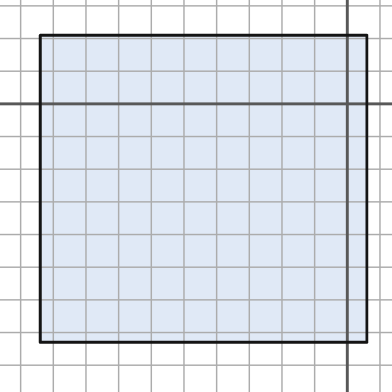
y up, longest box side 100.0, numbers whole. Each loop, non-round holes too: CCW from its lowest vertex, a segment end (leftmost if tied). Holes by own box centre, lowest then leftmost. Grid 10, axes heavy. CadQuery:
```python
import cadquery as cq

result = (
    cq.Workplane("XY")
    .moveTo(-94.0, -73.0)
    .lineTo(6.0, -73.0)
    .lineTo(6.0, 21.0)
    .lineTo(-94.0, 21.0)
    .close()
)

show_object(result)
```